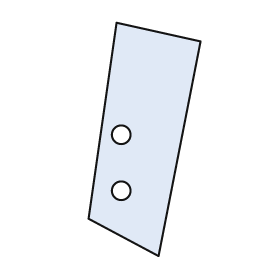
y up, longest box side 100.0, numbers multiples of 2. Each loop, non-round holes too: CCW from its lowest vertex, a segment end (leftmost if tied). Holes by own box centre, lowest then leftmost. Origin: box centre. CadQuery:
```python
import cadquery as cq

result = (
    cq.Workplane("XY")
    .moveTo(6.0, -50.0)
    .lineTo(24.0, 42.0)
    .lineTo(-12.0, 50.0)
    .lineTo(-24.0, -34.0)
    .close()
    .moveTo(-10.0, -22.0)
    .circle(4.0)
    .moveTo(-10.0, 2.0)
    .circle(4.0)
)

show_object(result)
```